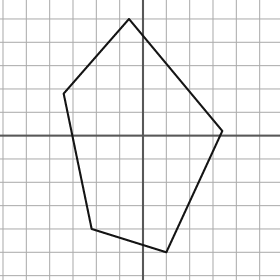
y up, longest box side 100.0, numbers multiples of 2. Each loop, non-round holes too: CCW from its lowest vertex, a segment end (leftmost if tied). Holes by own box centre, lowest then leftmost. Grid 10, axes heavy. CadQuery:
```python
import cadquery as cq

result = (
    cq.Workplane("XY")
    .moveTo(10.0, -50.0)
    .lineTo(34.0, 2.0)
    .lineTo(-6.0, 50.0)
    .lineTo(-34.0, 18.0)
    .lineTo(-22.0, -40.0)
    .close()
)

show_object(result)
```